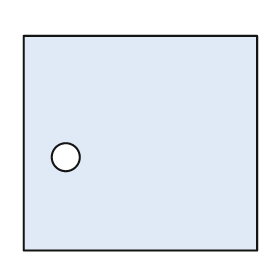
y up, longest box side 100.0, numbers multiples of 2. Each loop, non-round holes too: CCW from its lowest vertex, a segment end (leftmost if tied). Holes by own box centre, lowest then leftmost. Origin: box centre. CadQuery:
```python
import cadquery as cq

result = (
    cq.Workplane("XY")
    .moveTo(-50.0, -46.0)
    .lineTo(50.0, -46.0)
    .lineTo(50.0, 46.0)
    .lineTo(-50.0, 46.0)
    .close()
    .moveTo(-32.0, -6.0)
    .circle(6.0)
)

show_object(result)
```